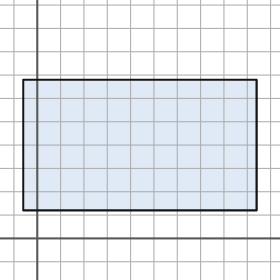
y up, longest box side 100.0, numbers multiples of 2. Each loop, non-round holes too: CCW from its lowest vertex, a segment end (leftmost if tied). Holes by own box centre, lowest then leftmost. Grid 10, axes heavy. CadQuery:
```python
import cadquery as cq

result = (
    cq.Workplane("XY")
    .moveTo(-6.0, 12.0)
    .lineTo(94.0, 12.0)
    .lineTo(94.0, 68.0)
    .lineTo(-6.0, 68.0)
    .close()
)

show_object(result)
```